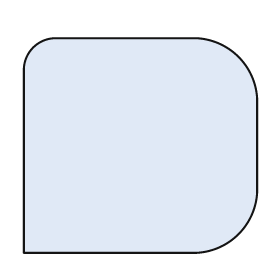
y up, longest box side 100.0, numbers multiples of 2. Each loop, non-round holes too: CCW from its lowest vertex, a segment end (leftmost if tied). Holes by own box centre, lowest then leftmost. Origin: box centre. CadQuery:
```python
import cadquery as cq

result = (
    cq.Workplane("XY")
    .moveTo(-50.0, -46.0)
    .lineTo(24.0, -46.0)
    .threePointArc((42.0, -38.0), (50.0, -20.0))
    .lineTo(50.0, 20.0)
    .threePointArc((42.0, 38.0), (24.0, 46.0))
    .lineTo(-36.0, 46.0)
    .threePointArc((-46.0, 42.0), (-50.0, 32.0))
    .close()
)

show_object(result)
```